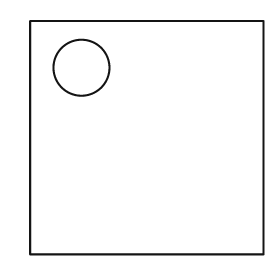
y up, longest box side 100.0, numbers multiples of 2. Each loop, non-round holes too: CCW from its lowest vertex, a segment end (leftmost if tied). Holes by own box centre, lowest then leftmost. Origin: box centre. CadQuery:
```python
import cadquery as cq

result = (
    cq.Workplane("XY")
    .moveTo(-50.0, -50.0)
    .lineTo(50.0, -50.0)
    .lineTo(50.0, 50.0)
    .lineTo(-50.0, 50.0)
    .close()
    .moveTo(-28.0, 30.0)
    .circle(12.0)
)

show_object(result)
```